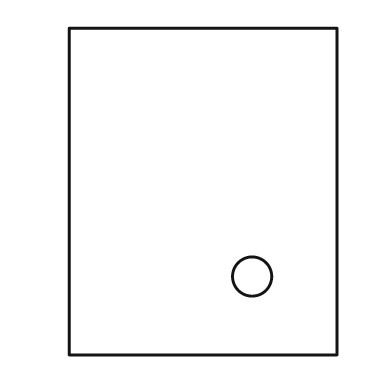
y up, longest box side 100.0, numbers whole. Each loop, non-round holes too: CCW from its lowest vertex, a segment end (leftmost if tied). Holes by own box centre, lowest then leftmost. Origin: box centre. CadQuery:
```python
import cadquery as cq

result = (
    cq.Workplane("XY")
    .moveTo(-41.0, -50.0)
    .lineTo(41.0, -50.0)
    .lineTo(41.0, 50.0)
    .lineTo(-41.0, 50.0)
    .close()
    .moveTo(15.0, -26.0)
    .circle(6.0)
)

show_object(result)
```